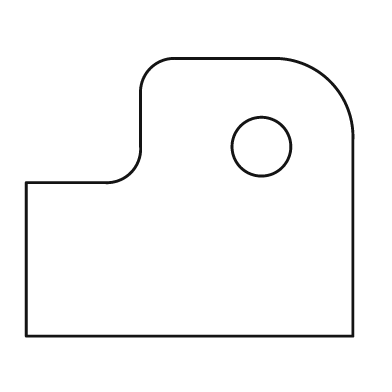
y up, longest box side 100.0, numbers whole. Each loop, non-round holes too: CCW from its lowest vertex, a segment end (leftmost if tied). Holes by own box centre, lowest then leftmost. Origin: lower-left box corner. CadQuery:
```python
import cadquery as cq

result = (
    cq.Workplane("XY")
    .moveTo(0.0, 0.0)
    .lineTo(100.0, 0.0)
    .lineTo(100.0, 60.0)
    .threePointArc((93.0, 78.0), (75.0, 85.0))
    .lineTo(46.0, 85.0)
    .threePointArc((38.0, 82.0), (35.0, 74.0))
    .lineTo(35.0, 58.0)
    .threePointArc((32.0, 50.0), (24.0, 47.0))
    .lineTo(0.0, 47.0)
    .close()
    .moveTo(72.0, 58.0)
    .circle(9.0)
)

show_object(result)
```